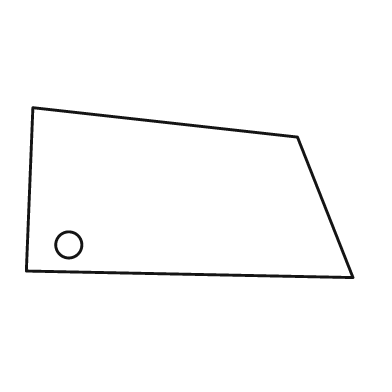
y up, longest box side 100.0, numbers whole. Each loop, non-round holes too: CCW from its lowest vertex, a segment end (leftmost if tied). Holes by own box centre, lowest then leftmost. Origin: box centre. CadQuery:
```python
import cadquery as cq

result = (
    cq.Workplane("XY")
    .moveTo(50.0, -26.0)
    .lineTo(33.0, 17.0)
    .lineTo(-48.0, 26.0)
    .lineTo(-50.0, -24.0)
    .close()
    .moveTo(-37.0, -16.0)
    .circle(4.0)
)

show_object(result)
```